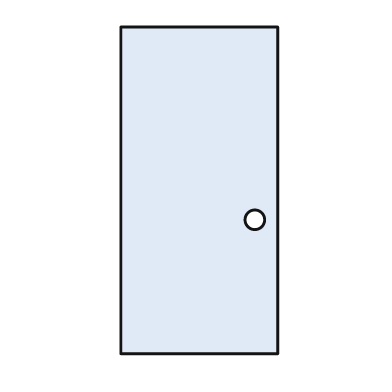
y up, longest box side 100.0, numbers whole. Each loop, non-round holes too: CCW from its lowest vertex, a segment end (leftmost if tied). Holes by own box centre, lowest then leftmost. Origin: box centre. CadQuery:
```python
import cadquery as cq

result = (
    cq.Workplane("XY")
    .moveTo(-24.0, -50.0)
    .lineTo(24.0, -50.0)
    .lineTo(24.0, 50.0)
    .lineTo(-24.0, 50.0)
    .close()
    .moveTo(17.0, -9.0)
    .circle(3.0)
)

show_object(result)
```